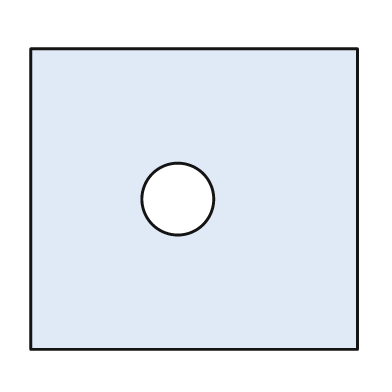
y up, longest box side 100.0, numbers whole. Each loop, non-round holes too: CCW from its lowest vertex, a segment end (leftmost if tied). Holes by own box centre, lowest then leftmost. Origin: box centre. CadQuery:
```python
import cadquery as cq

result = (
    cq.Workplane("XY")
    .moveTo(-50.0, -46.0)
    .lineTo(50.0, -46.0)
    .lineTo(50.0, 46.0)
    .lineTo(-50.0, 46.0)
    .close()
    .moveTo(-5.0, 0.0)
    .circle(11.0)
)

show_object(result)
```